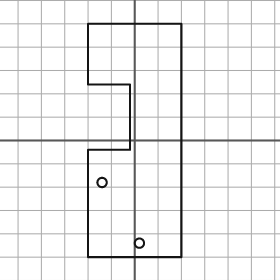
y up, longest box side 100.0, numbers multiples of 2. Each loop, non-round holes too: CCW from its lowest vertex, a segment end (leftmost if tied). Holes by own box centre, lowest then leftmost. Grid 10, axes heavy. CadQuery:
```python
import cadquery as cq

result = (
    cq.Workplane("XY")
    .moveTo(-20.0, -50.0)
    .lineTo(20.0, -50.0)
    .lineTo(20.0, 50.0)
    .lineTo(-20.0, 50.0)
    .lineTo(-20.0, 24.0)
    .lineTo(-2.0, 24.0)
    .lineTo(-2.0, -4.0)
    .lineTo(-20.0, -4.0)
    .close()
    .moveTo(2.0, -44.0)
    .circle(2.0)
    .moveTo(-14.0, -18.0)
    .circle(2.0)
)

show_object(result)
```